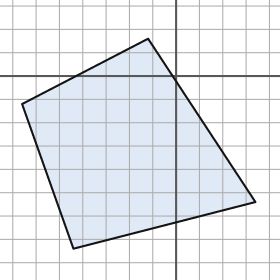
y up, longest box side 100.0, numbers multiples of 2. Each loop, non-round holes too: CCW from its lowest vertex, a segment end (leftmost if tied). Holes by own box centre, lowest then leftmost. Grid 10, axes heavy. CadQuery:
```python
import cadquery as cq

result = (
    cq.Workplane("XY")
    .moveTo(-44.0, -74.0)
    .lineTo(34.0, -54.0)
    .lineTo(-12.0, 16.0)
    .lineTo(-66.0, -12.0)
    .close()
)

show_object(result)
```